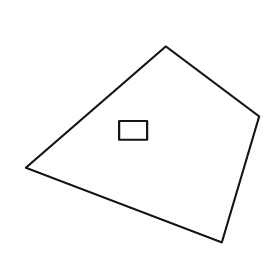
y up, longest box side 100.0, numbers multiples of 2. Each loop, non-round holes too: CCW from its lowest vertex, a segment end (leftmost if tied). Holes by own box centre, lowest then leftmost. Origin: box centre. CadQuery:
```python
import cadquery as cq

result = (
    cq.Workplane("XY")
    .moveTo(34.0, -42.0)
    .lineTo(50.0, 12.0)
    .lineTo(10.0, 42.0)
    .lineTo(-50.0, -10.0)
    .close()
    .moveTo(-10.0, 2.0)
    .lineTo(2.0, 2.0)
    .lineTo(2.0, 10.0)
    .lineTo(-10.0, 10.0)
    .close()
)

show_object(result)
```